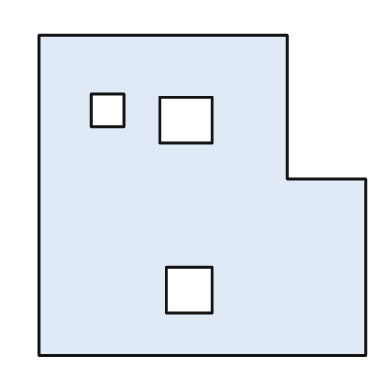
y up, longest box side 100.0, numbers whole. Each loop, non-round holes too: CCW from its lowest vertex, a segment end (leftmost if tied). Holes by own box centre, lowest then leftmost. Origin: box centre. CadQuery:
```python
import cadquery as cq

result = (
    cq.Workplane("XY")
    .moveTo(-50.0, -49.0)
    .lineTo(50.0, -49.0)
    .lineTo(50.0, 5.0)
    .lineTo(26.0, 5.0)
    .lineTo(26.0, 49.0)
    .lineTo(-50.0, 49.0)
    .close()
    .moveTo(-11.0, -36.0)
    .lineTo(3.0, -36.0)
    .lineTo(3.0, -22.0)
    .lineTo(-11.0, -22.0)
    .close()
    .moveTo(-13.0, 16.0)
    .lineTo(3.0, 16.0)
    .lineTo(3.0, 30.0)
    .lineTo(-13.0, 30.0)
    .close()
    .moveTo(-34.0, 21.0)
    .lineTo(-24.0, 21.0)
    .lineTo(-24.0, 31.0)
    .lineTo(-34.0, 31.0)
    .close()
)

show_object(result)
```